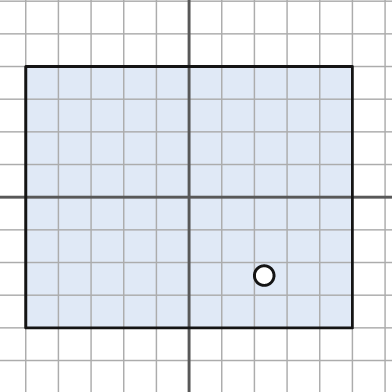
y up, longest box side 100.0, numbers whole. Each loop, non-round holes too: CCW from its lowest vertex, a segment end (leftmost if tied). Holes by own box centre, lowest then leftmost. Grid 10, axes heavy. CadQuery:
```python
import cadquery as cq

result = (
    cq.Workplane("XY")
    .moveTo(-50.0, -40.0)
    .lineTo(50.0, -40.0)
    .lineTo(50.0, 40.0)
    .lineTo(-50.0, 40.0)
    .close()
    .moveTo(23.0, -24.0)
    .circle(3.0)
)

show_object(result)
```